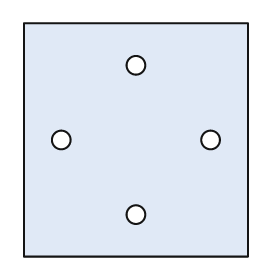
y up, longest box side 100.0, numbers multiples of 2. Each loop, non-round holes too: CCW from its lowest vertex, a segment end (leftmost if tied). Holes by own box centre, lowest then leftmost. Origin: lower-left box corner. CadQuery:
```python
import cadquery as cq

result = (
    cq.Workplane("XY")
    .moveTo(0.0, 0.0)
    .lineTo(96.0, 0.0)
    .lineTo(96.0, 100.0)
    .lineTo(0.0, 100.0)
    .close()
    .moveTo(48.0, 18.0)
    .circle(4.0)
    .moveTo(16.0, 50.0)
    .circle(4.0)
    .moveTo(80.0, 50.0)
    .circle(4.0)
    .moveTo(48.0, 82.0)
    .circle(4.0)
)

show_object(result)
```